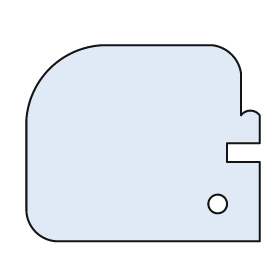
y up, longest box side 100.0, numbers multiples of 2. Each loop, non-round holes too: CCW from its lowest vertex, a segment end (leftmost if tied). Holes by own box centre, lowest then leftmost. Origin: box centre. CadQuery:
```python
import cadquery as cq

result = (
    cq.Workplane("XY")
    .moveTo(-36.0, -42.0)
    .lineTo(50.0, -42.0)
    .lineTo(50.0, -8.0)
    .lineTo(36.0, -8.0)
    .lineTo(36.0, 0.0)
    .lineTo(50.0, 0.0)
    .lineTo(50.0, 12.0)
    .threePointArc((46.0, 14.0), (42.0, 12.0))
    .lineTo(42.0, 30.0)
    .threePointArc((38.0, 38.0), (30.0, 42.0))
    .lineTo(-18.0, 42.0)
    .threePointArc((-40.0, 32.0), (-50.0, 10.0))
    .lineTo(-50.0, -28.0)
    .threePointArc((-46.0, -38.0), (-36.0, -42.0))
    .close()
    .moveTo(32.0, -26.0)
    .circle(4.0)
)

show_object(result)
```